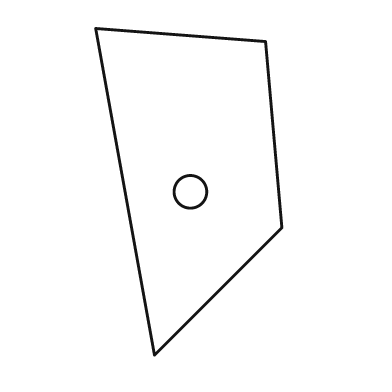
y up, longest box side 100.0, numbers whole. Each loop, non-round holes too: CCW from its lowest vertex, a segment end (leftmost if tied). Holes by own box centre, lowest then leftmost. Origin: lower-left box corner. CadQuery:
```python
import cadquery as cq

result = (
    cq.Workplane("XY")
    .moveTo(18.0, 0.0)
    .lineTo(57.0, 39.0)
    .lineTo(52.0, 96.0)
    .lineTo(0.0, 100.0)
    .close()
    .moveTo(29.0, 50.0)
    .circle(5.0)
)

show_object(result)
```